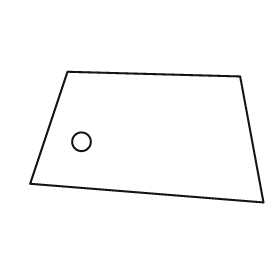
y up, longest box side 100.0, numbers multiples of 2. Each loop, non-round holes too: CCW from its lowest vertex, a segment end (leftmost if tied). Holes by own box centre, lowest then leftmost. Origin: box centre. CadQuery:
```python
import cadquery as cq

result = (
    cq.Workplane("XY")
    .moveTo(50.0, -28.0)
    .lineTo(40.0, 26.0)
    .lineTo(-34.0, 28.0)
    .lineTo(-50.0, -20.0)
    .close()
    .moveTo(-28.0, -2.0)
    .circle(4.0)
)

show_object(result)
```